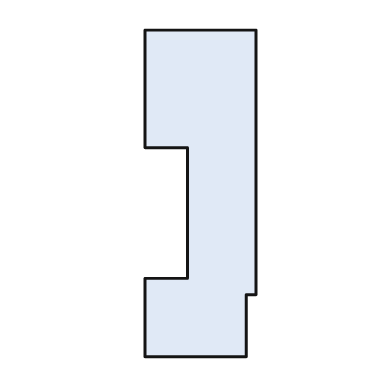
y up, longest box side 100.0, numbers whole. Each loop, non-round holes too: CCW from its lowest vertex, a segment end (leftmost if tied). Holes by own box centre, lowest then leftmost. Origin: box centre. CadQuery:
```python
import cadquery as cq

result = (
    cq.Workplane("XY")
    .moveTo(-17.0, -50.0)
    .lineTo(14.0, -50.0)
    .lineTo(14.0, -31.0)
    .lineTo(17.0, -31.0)
    .lineTo(17.0, 50.0)
    .lineTo(-17.0, 50.0)
    .lineTo(-17.0, 14.0)
    .lineTo(-4.0, 14.0)
    .lineTo(-4.0, -26.0)
    .lineTo(-17.0, -26.0)
    .close()
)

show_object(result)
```